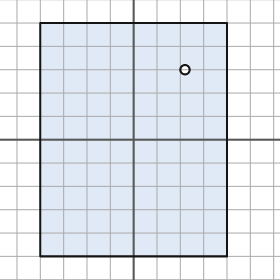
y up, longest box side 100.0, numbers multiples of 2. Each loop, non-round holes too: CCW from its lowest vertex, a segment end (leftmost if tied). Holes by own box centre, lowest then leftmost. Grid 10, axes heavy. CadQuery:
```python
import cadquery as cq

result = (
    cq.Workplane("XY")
    .moveTo(-40.0, -50.0)
    .lineTo(40.0, -50.0)
    .lineTo(40.0, 50.0)
    .lineTo(-40.0, 50.0)
    .close()
    .moveTo(22.0, 30.0)
    .circle(2.0)
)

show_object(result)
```